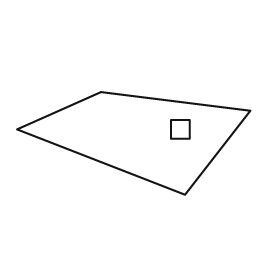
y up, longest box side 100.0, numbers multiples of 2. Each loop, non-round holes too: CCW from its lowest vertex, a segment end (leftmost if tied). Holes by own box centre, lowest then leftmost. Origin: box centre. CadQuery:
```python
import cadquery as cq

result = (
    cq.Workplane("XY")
    .moveTo(22.0, -22.0)
    .lineTo(50.0, 14.0)
    .lineTo(-14.0, 22.0)
    .lineTo(-50.0, 6.0)
    .close()
    .moveTo(16.0, 2.0)
    .lineTo(24.0, 2.0)
    .lineTo(24.0, 10.0)
    .lineTo(16.0, 10.0)
    .close()
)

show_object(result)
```